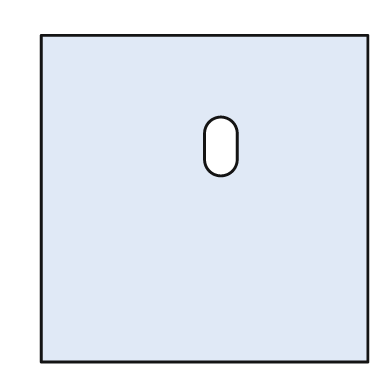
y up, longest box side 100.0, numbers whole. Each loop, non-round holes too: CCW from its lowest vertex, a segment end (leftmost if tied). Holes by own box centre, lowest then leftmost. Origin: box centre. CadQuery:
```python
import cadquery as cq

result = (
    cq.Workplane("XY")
    .moveTo(-50.0, -50.0)
    .lineTo(50.0, -50.0)
    .lineTo(50.0, 50.0)
    .lineTo(-50.0, 50.0)
    .close()
    .moveTo(0.0, 12.0)
    .threePointArc((5.0, 7.0), (10.0, 12.0))
    .lineTo(10.0, 20.0)
    .threePointArc((5.0, 25.0), (0.0, 20.0))
    .close()
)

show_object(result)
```